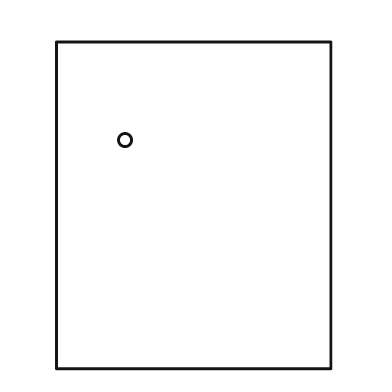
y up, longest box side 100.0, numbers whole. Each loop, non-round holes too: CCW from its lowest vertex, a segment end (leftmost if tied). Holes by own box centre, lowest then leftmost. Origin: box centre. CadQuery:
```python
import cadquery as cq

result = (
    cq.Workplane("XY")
    .moveTo(-42.0, -50.0)
    .lineTo(42.0, -50.0)
    .lineTo(42.0, 50.0)
    .lineTo(-42.0, 50.0)
    .close()
    .moveTo(-21.0, 20.0)
    .circle(2.0)
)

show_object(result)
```